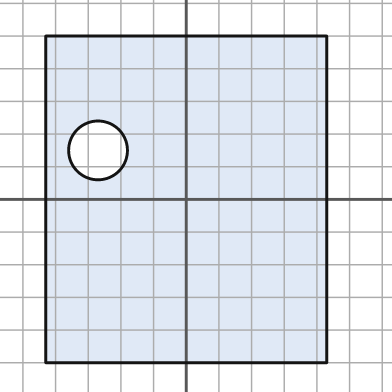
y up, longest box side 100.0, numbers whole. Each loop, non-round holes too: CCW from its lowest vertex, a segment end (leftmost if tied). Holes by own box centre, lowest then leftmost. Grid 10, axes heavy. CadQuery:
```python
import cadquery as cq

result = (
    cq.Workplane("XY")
    .moveTo(-43.0, -50.0)
    .lineTo(43.0, -50.0)
    .lineTo(43.0, 50.0)
    .lineTo(-43.0, 50.0)
    .close()
    .moveTo(-27.0, 15.0)
    .circle(9.0)
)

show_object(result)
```